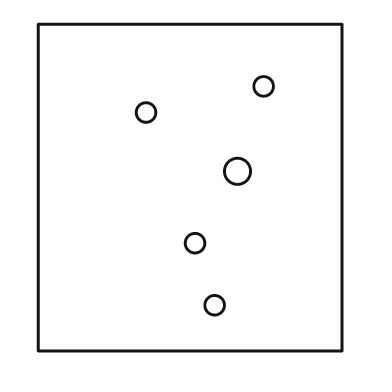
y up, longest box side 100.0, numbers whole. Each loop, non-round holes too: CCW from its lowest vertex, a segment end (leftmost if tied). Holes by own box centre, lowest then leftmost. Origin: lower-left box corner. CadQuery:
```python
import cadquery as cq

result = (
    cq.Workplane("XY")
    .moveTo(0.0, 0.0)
    .lineTo(93.0, 0.0)
    .lineTo(93.0, 100.0)
    .lineTo(0.0, 100.0)
    .close()
    .moveTo(54.0, 14.0)
    .circle(3.0)
    .moveTo(48.0, 33.0)
    .circle(3.0)
    .moveTo(61.0, 55.0)
    .circle(4.0)
    .moveTo(33.0, 73.0)
    .circle(3.0)
    .moveTo(69.0, 81.0)
    .circle(3.0)
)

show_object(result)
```